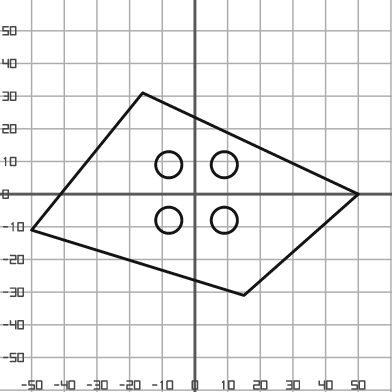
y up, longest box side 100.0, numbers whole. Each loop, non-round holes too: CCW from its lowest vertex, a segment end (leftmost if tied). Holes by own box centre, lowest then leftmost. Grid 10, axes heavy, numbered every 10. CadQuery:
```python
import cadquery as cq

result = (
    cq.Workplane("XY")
    .moveTo(15.0, -31.0)
    .lineTo(50.0, 0.0)
    .lineTo(-16.0, 31.0)
    .lineTo(-50.0, -11.0)
    .close()
    .moveTo(-8.0, -8.0)
    .circle(4.0)
    .moveTo(9.0, -8.0)
    .circle(4.0)
    .moveTo(-8.0, 9.0)
    .circle(4.0)
    .moveTo(9.0, 9.0)
    .circle(4.0)
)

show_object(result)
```